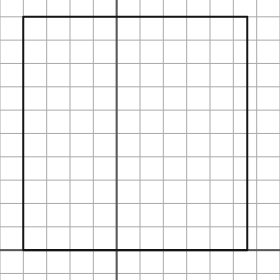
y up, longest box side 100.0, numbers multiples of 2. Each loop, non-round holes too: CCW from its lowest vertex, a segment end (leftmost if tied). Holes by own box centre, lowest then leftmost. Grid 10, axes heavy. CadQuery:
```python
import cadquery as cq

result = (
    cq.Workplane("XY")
    .moveTo(-40.0, 0.0)
    .lineTo(56.0, 0.0)
    .lineTo(56.0, 100.0)
    .lineTo(-40.0, 100.0)
    .close()
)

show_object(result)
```